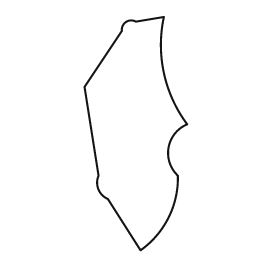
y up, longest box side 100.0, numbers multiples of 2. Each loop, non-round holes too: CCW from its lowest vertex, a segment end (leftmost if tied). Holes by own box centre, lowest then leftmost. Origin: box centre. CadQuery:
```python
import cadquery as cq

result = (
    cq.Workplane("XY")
    .moveTo(2.0, -50.0)
    .threePointArc((14.0, -36.0), (18.0, -18.0))
    .threePointArc((14.0, -6.0), (22.0, 4.0))
    .threePointArc((12.0, 26.0), (12.0, 50.0))
    .lineTo(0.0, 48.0)
    .threePointArc((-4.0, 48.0), (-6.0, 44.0))
    .lineTo(-22.0, 20.0)
    .lineTo(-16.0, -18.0)
    .threePointArc((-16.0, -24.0), (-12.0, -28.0))
    .close()
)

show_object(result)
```